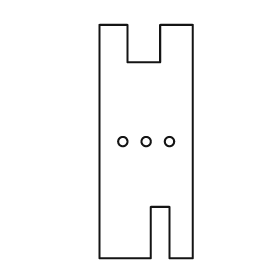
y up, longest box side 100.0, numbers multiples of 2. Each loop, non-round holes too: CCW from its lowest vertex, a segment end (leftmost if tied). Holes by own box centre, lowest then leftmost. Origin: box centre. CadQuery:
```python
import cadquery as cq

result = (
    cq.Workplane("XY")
    .moveTo(-20.0, -50.0)
    .lineTo(2.0, -50.0)
    .lineTo(2.0, -28.0)
    .lineTo(10.0, -28.0)
    .lineTo(10.0, -50.0)
    .lineTo(20.0, -50.0)
    .lineTo(20.0, 50.0)
    .lineTo(6.0, 50.0)
    .lineTo(6.0, 34.0)
    .lineTo(-8.0, 34.0)
    .lineTo(-8.0, 50.0)
    .lineTo(-20.0, 50.0)
    .close()
    .moveTo(-10.0, 0.0)
    .circle(2.0)
    .moveTo(0.0, 0.0)
    .circle(2.0)
    .moveTo(10.0, 0.0)
    .circle(2.0)
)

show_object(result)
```